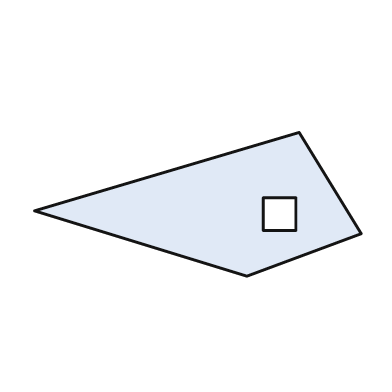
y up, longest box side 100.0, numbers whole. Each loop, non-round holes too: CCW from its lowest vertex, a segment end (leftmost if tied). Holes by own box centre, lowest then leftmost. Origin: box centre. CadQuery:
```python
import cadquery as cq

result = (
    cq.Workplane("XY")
    .moveTo(15.0, -22.0)
    .lineTo(50.0, -9.0)
    .lineTo(31.0, 22.0)
    .lineTo(-50.0, -2.0)
    .close()
    .moveTo(20.0, -8.0)
    .lineTo(30.0, -8.0)
    .lineTo(30.0, 2.0)
    .lineTo(20.0, 2.0)
    .close()
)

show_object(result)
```